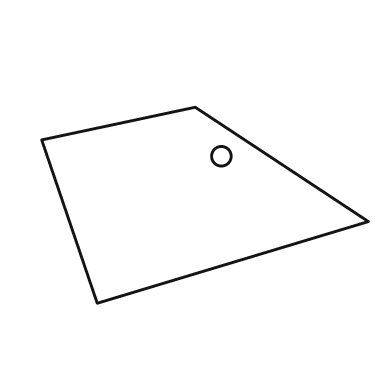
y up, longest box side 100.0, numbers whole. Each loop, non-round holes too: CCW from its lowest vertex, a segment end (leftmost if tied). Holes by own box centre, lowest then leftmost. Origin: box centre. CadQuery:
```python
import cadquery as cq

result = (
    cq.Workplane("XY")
    .moveTo(-33.0, -30.0)
    .lineTo(50.0, -5.0)
    .lineTo(-3.0, 30.0)
    .lineTo(-50.0, 20.0)
    .close()
    .moveTo(5.0, 15.0)
    .circle(3.0)
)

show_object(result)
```